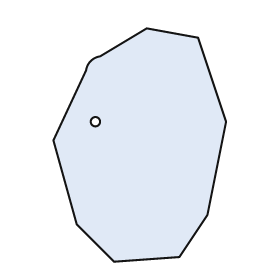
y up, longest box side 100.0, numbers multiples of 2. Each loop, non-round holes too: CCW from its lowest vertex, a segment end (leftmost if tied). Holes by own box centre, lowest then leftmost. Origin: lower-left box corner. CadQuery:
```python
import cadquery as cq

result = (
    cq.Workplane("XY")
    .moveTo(26.0, 0.0)
    .lineTo(54.0, 2.0)
    .lineTo(66.0, 20.0)
    .lineTo(74.0, 60.0)
    .lineTo(62.0, 96.0)
    .lineTo(40.0, 100.0)
    .lineTo(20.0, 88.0)
    .threePointArc((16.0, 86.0), (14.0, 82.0))
    .lineTo(0.0, 52.0)
    .lineTo(10.0, 16.0)
    .close()
    .moveTo(18.0, 60.0)
    .circle(2.0)
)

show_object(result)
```